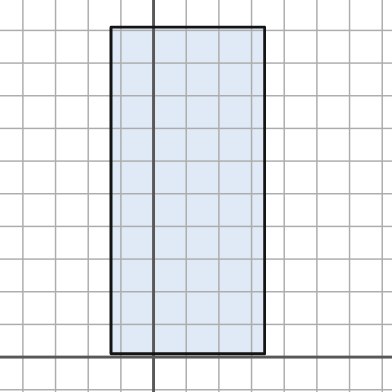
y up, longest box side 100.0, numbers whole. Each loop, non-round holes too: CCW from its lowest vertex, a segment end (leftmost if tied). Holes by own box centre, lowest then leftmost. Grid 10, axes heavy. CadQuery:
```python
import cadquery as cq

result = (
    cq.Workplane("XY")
    .moveTo(-13.0, 1.0)
    .lineTo(34.0, 1.0)
    .lineTo(34.0, 101.0)
    .lineTo(-13.0, 101.0)
    .close()
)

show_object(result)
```